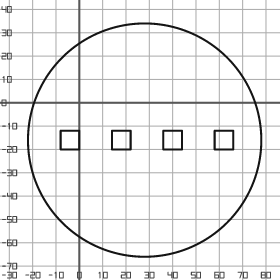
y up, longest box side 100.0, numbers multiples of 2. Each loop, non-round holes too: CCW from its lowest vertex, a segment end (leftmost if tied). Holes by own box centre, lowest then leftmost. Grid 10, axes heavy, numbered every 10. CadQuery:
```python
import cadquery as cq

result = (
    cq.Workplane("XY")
    .moveTo(28.0, -16.0)
    .circle(50.0)
    .moveTo(-8.0, -20.0)
    .lineTo(0.0, -20.0)
    .lineTo(0.0, -12.0)
    .lineTo(-8.0, -12.0)
    .close()
    .moveTo(14.0, -20.0)
    .lineTo(22.0, -20.0)
    .lineTo(22.0, -12.0)
    .lineTo(14.0, -12.0)
    .close()
    .moveTo(36.0, -20.0)
    .lineTo(44.0, -20.0)
    .lineTo(44.0, -12.0)
    .lineTo(36.0, -12.0)
    .close()
    .moveTo(58.0, -20.0)
    .lineTo(66.0, -20.0)
    .lineTo(66.0, -12.0)
    .lineTo(58.0, -12.0)
    .close()
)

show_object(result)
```